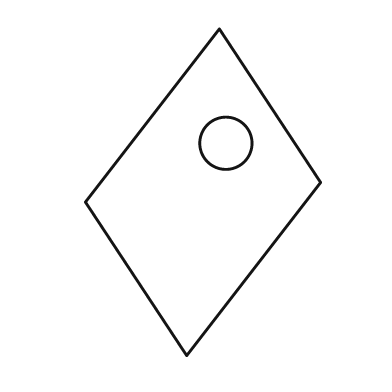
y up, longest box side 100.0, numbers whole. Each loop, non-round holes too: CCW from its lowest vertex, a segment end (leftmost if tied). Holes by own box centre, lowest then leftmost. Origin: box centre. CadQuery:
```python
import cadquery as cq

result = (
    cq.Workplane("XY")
    .moveTo(-5.0, -50.0)
    .lineTo(36.0, 3.0)
    .lineTo(5.0, 50.0)
    .lineTo(-36.0, -3.0)
    .close()
    .moveTo(7.0, 15.0)
    .circle(8.0)
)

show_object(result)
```